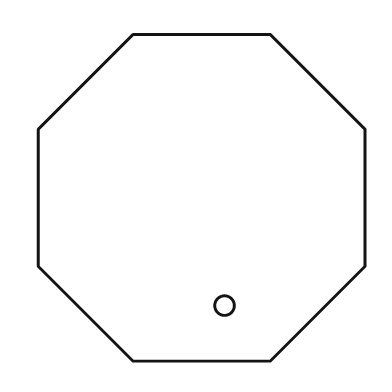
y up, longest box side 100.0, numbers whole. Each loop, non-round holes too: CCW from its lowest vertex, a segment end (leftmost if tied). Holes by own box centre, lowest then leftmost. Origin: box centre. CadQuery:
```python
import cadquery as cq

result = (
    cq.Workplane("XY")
    .moveTo(-21.0, -50.0)
    .lineTo(21.0, -50.0)
    .lineTo(50.0, -21.0)
    .lineTo(50.0, 21.0)
    .lineTo(21.0, 50.0)
    .lineTo(-21.0, 50.0)
    .lineTo(-50.0, 21.0)
    .lineTo(-50.0, -21.0)
    .close()
    .moveTo(7.0, -33.0)
    .circle(3.0)
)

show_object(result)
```